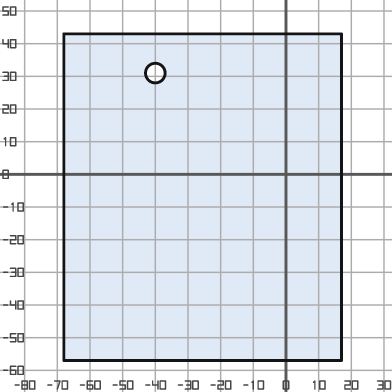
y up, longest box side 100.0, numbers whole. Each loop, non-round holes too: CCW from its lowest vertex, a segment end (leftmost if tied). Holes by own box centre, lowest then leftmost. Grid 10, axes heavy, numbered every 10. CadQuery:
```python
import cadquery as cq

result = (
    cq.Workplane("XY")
    .moveTo(-68.0, -57.0)
    .lineTo(17.0, -57.0)
    .lineTo(17.0, 43.0)
    .lineTo(-68.0, 43.0)
    .close()
    .moveTo(-40.0, 31.0)
    .circle(3.0)
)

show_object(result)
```